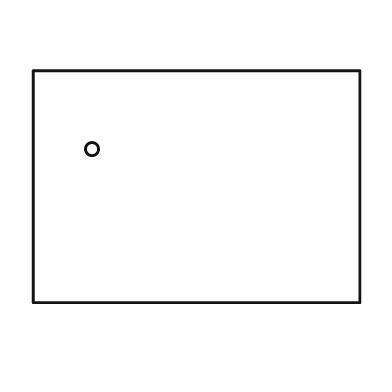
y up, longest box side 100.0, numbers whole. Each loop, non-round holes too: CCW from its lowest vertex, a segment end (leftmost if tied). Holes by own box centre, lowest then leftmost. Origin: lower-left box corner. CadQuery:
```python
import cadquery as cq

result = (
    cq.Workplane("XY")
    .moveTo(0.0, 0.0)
    .lineTo(100.0, 0.0)
    .lineTo(100.0, 71.0)
    .lineTo(0.0, 71.0)
    .close()
    .moveTo(18.0, 47.0)
    .circle(2.0)
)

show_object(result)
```